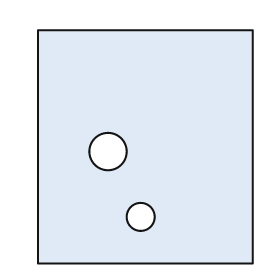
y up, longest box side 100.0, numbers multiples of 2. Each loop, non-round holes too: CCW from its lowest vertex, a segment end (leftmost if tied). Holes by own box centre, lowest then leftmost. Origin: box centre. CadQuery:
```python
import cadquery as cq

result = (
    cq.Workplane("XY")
    .moveTo(-46.0, -50.0)
    .lineTo(46.0, -50.0)
    .lineTo(46.0, 50.0)
    .lineTo(-46.0, 50.0)
    .close()
    .moveTo(-2.0, -30.0)
    .circle(6.0)
    .moveTo(-16.0, -2.0)
    .circle(8.0)
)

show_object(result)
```